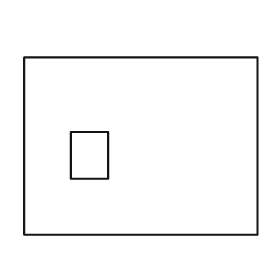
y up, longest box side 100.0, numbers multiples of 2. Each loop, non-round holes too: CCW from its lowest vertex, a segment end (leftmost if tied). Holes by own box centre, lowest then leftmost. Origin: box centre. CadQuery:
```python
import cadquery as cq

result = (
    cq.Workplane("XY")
    .moveTo(-50.0, -38.0)
    .lineTo(50.0, -38.0)
    .lineTo(50.0, 38.0)
    .lineTo(-50.0, 38.0)
    .close()
    .moveTo(-30.0, -14.0)
    .lineTo(-14.0, -14.0)
    .lineTo(-14.0, 6.0)
    .lineTo(-30.0, 6.0)
    .close()
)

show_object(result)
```